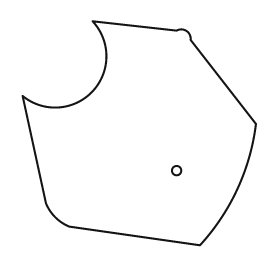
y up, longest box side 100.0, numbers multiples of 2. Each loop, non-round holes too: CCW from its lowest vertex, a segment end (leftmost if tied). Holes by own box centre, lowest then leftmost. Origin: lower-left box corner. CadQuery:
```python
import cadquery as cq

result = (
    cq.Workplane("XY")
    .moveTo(76.0, 0.0)
    .threePointArc((92.0, 24.0), (100.0, 52.0))
    .lineTo(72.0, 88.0)
    .threePointArc((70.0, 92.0), (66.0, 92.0))
    .lineTo(30.0, 96.0)
    .threePointArc((30.0, 66.0), (0.0, 64.0))
    .lineTo(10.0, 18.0)
    .threePointArc((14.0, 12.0), (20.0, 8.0))
    .close()
    .moveTo(66.0, 32.0)
    .circle(2.0)
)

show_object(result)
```